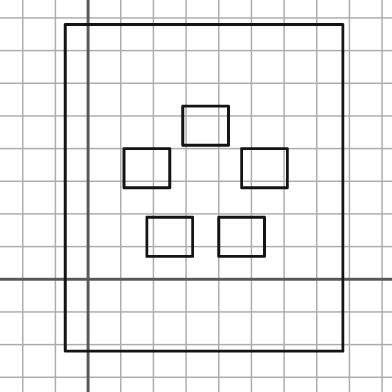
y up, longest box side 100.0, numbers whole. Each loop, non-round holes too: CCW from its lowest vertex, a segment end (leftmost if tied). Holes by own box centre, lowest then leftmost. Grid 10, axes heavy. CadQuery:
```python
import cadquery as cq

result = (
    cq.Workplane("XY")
    .moveTo(-7.0, -22.0)
    .lineTo(78.0, -22.0)
    .lineTo(78.0, 78.0)
    .lineTo(-7.0, 78.0)
    .close()
    .moveTo(18.0, 7.0)
    .lineTo(32.0, 7.0)
    .lineTo(32.0, 19.0)
    .lineTo(18.0, 19.0)
    .close()
    .moveTo(40.0, 7.0)
    .lineTo(54.0, 7.0)
    .lineTo(54.0, 19.0)
    .lineTo(40.0, 19.0)
    .close()
    .moveTo(11.0, 28.0)
    .lineTo(25.0, 28.0)
    .lineTo(25.0, 40.0)
    .lineTo(11.0, 40.0)
    .close()
    .moveTo(47.0, 28.0)
    .lineTo(61.0, 28.0)
    .lineTo(61.0, 40.0)
    .lineTo(47.0, 40.0)
    .close()
    .moveTo(29.0, 41.0)
    .lineTo(43.0, 41.0)
    .lineTo(43.0, 53.0)
    .lineTo(29.0, 53.0)
    .close()
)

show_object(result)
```